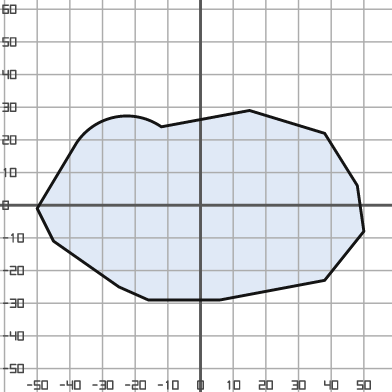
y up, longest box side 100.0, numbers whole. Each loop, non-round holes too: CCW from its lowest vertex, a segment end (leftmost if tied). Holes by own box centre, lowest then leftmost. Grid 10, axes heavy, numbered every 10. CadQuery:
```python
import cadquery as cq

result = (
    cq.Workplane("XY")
    .moveTo(-16.0, -29.0)
    .lineTo(6.0, -29.0)
    .lineTo(38.0, -23.0)
    .lineTo(50.0, -8.0)
    .lineTo(48.0, 6.0)
    .lineTo(38.0, 22.0)
    .lineTo(15.0, 29.0)
    .lineTo(-12.0, 24.0)
    .threePointArc((-26.0, 27.0), (-38.0, 19.0))
    .lineTo(-50.0, -1.0)
    .lineTo(-45.0, -11.0)
    .lineTo(-25.0, -25.0)
    .close()
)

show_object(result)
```